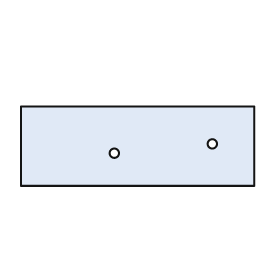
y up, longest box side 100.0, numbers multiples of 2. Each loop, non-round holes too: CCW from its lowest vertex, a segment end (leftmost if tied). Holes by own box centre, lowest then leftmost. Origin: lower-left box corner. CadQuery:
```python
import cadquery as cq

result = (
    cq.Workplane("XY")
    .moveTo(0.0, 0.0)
    .lineTo(100.0, 0.0)
    .lineTo(100.0, 34.0)
    .lineTo(0.0, 34.0)
    .close()
    .moveTo(40.0, 14.0)
    .circle(2.0)
    .moveTo(82.0, 18.0)
    .circle(2.0)
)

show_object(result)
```